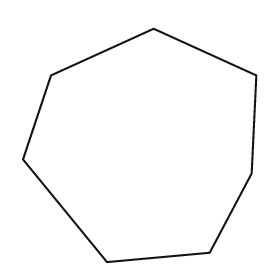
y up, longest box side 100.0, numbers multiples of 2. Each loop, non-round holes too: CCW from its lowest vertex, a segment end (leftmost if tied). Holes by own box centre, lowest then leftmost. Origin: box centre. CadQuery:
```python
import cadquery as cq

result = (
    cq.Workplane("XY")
    .moveTo(-14.0, -50.0)
    .lineTo(30.0, -46.0)
    .lineTo(48.0, -12.0)
    .lineTo(50.0, 30.0)
    .lineTo(6.0, 50.0)
    .lineTo(-38.0, 30.0)
    .lineTo(-50.0, -6.0)
    .close()
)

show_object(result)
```